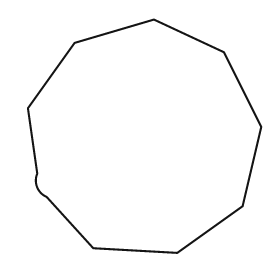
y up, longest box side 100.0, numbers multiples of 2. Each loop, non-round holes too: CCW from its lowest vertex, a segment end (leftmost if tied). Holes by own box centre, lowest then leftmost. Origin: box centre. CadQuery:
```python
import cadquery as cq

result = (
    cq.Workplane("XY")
    .moveTo(14.0, -50.0)
    .lineTo(42.0, -30.0)
    .lineTo(50.0, 4.0)
    .lineTo(34.0, 36.0)
    .lineTo(4.0, 50.0)
    .lineTo(-30.0, 40.0)
    .lineTo(-50.0, 12.0)
    .lineTo(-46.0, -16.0)
    .threePointArc((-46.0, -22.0), (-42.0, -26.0))
    .lineTo(-22.0, -48.0)
    .close()
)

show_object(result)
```